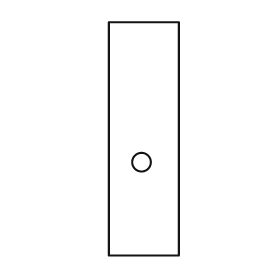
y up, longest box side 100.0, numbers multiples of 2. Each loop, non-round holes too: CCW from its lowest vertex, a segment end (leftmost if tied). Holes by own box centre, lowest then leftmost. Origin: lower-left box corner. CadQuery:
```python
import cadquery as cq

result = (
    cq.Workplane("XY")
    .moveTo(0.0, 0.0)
    .lineTo(30.0, 0.0)
    .lineTo(30.0, 100.0)
    .lineTo(0.0, 100.0)
    .close()
    .moveTo(14.0, 40.0)
    .circle(4.0)
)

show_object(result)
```